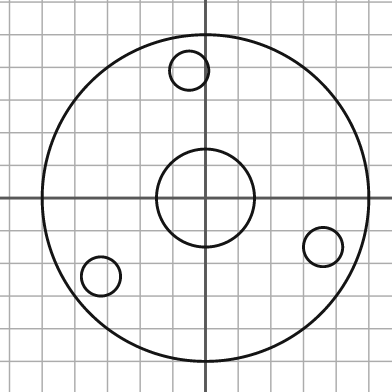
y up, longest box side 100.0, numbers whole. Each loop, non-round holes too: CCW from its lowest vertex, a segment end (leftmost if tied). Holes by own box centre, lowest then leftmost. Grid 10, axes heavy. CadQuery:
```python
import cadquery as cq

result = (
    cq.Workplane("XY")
    .moveTo(0.0, 0.0)
    .circle(50.0)
    .moveTo(-32.0, -24.0)
    .circle(6.0)
    .moveTo(36.0, -15.0)
    .circle(6.0)
    .moveTo(0.0, 0.0)
    .circle(15.0)
    .moveTo(-5.0, 39.0)
    .circle(6.0)
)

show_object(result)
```